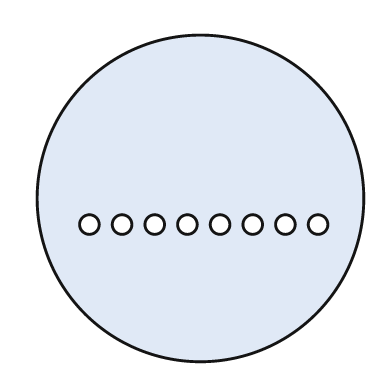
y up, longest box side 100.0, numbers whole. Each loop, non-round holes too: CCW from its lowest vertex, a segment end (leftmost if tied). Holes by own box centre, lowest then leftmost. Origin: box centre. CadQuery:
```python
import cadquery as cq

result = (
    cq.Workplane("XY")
    .moveTo(0.0, 0.0)
    .circle(50.0)
    .moveTo(-34.0, -8.0)
    .circle(3.0)
    .moveTo(-24.0, -8.0)
    .circle(3.0)
    .moveTo(-14.0, -8.0)
    .circle(3.0)
    .moveTo(-4.0, -8.0)
    .circle(3.0)
    .moveTo(6.0, -8.0)
    .circle(3.0)
    .moveTo(16.0, -8.0)
    .circle(3.0)
    .moveTo(26.0, -8.0)
    .circle(3.0)
    .moveTo(36.0, -8.0)
    .circle(3.0)
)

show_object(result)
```